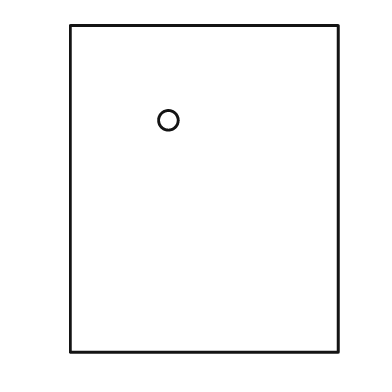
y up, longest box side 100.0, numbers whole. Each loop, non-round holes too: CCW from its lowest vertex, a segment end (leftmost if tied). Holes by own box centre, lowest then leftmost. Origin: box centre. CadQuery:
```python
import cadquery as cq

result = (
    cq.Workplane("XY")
    .moveTo(-41.0, -50.0)
    .lineTo(41.0, -50.0)
    .lineTo(41.0, 50.0)
    .lineTo(-41.0, 50.0)
    .close()
    .moveTo(-11.0, 21.0)
    .circle(3.0)
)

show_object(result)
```